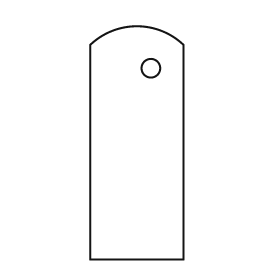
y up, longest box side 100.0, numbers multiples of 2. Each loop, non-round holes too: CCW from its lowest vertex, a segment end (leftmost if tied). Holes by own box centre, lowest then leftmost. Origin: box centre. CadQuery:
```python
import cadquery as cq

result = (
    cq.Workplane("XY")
    .moveTo(-20.0, -50.0)
    .lineTo(20.0, -50.0)
    .lineTo(20.0, 42.0)
    .threePointArc((0.0, 50.0), (-20.0, 42.0))
    .close()
    .moveTo(6.0, 32.0)
    .circle(4.0)
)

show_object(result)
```